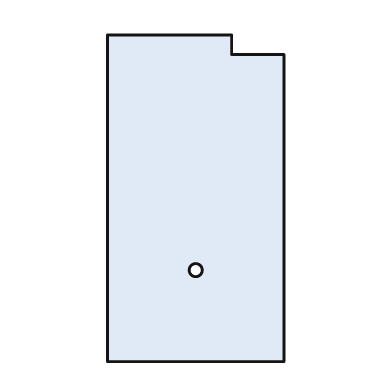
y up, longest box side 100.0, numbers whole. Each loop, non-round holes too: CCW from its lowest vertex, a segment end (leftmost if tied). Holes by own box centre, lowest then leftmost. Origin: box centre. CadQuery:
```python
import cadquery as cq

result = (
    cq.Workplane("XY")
    .moveTo(-27.0, -50.0)
    .lineTo(27.0, -50.0)
    .lineTo(27.0, 44.0)
    .lineTo(11.0, 44.0)
    .lineTo(11.0, 50.0)
    .lineTo(-27.0, 50.0)
    .close()
    .moveTo(0.0, -22.0)
    .circle(2.0)
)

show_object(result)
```